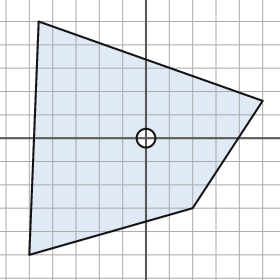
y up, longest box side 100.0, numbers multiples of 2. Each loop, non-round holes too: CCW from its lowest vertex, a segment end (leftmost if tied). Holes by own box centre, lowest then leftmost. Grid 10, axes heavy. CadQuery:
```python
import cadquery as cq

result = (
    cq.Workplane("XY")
    .moveTo(-50.0, -50.0)
    .lineTo(20.0, -30.0)
    .lineTo(50.0, 16.0)
    .lineTo(-46.0, 50.0)
    .close()
    .moveTo(0.0, 0.0)
    .circle(4.0)
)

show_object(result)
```